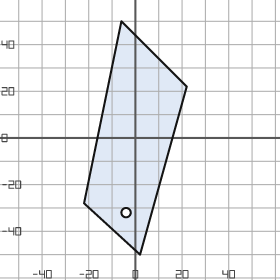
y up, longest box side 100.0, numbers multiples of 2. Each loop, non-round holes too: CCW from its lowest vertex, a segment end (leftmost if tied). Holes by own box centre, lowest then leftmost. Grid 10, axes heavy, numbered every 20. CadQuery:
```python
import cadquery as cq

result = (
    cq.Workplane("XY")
    .moveTo(2.0, -50.0)
    .lineTo(22.0, 22.0)
    .lineTo(-6.0, 50.0)
    .lineTo(-22.0, -28.0)
    .close()
    .moveTo(-4.0, -32.0)
    .circle(2.0)
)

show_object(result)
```